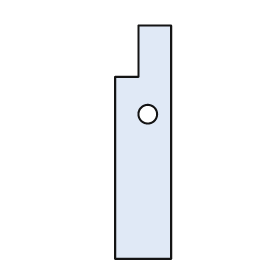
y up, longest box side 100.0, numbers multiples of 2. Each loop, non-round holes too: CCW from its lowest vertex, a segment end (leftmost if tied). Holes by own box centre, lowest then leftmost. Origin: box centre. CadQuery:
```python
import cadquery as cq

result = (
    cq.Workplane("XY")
    .moveTo(-12.0, -50.0)
    .lineTo(12.0, -50.0)
    .lineTo(12.0, 50.0)
    .lineTo(-2.0, 50.0)
    .lineTo(-2.0, 28.0)
    .lineTo(-12.0, 28.0)
    .close()
    .moveTo(2.0, 12.0)
    .circle(4.0)
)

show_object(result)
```